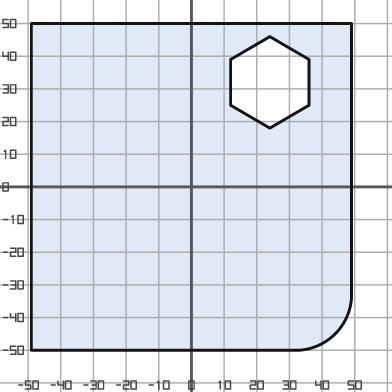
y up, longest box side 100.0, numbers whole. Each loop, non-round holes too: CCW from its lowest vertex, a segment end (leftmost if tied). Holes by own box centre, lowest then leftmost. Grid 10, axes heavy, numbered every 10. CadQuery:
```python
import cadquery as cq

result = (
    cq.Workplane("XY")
    .moveTo(-49.0, -50.0)
    .lineTo(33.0, -50.0)
    .threePointArc((44.0, -45.0), (49.0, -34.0))
    .lineTo(49.0, 50.0)
    .lineTo(-49.0, 50.0)
    .close()
    .moveTo(24.0, 18.0)
    .lineTo(36.0, 25.0)
    .lineTo(36.0, 39.0)
    .lineTo(24.0, 46.0)
    .lineTo(12.0, 39.0)
    .lineTo(12.0, 25.0)
    .close()
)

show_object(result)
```